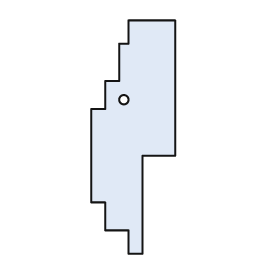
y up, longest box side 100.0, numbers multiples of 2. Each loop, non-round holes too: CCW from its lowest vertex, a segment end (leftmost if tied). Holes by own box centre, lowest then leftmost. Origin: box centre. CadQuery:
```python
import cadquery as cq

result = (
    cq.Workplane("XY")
    .moveTo(-2.0, -50.0)
    .lineTo(4.0, -50.0)
    .lineTo(4.0, -8.0)
    .lineTo(18.0, -8.0)
    .lineTo(18.0, 50.0)
    .lineTo(-2.0, 50.0)
    .lineTo(-2.0, 40.0)
    .lineTo(-6.0, 40.0)
    .lineTo(-6.0, 24.0)
    .lineTo(-12.0, 24.0)
    .lineTo(-12.0, 12.0)
    .lineTo(-18.0, 12.0)
    .lineTo(-18.0, -28.0)
    .lineTo(-12.0, -28.0)
    .lineTo(-12.0, -40.0)
    .lineTo(-2.0, -40.0)
    .close()
    .moveTo(-4.0, 16.0)
    .circle(2.0)
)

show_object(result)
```